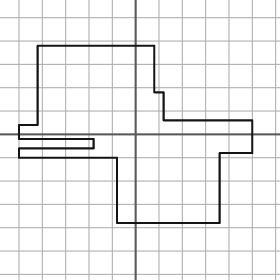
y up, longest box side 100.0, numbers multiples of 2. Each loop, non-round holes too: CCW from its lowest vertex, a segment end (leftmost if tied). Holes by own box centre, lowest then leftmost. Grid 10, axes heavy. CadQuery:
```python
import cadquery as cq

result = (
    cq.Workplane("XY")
    .moveTo(-8.0, -38.0)
    .lineTo(36.0, -38.0)
    .lineTo(36.0, -8.0)
    .lineTo(50.0, -8.0)
    .lineTo(50.0, 6.0)
    .lineTo(12.0, 6.0)
    .lineTo(12.0, 18.0)
    .lineTo(8.0, 18.0)
    .lineTo(8.0, 38.0)
    .lineTo(-42.0, 38.0)
    .lineTo(-42.0, 4.0)
    .lineTo(-50.0, 4.0)
    .lineTo(-50.0, -2.0)
    .lineTo(-18.0, -2.0)
    .lineTo(-18.0, -6.0)
    .lineTo(-50.0, -6.0)
    .lineTo(-50.0, -10.0)
    .lineTo(-8.0, -10.0)
    .close()
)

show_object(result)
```